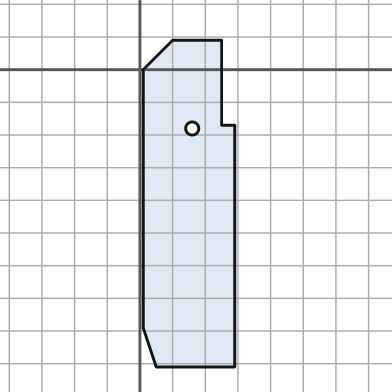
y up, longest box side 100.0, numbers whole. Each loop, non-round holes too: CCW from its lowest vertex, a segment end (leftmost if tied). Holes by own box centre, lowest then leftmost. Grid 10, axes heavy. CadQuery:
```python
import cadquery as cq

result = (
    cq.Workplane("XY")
    .moveTo(5.0, -91.0)
    .lineTo(29.0, -91.0)
    .lineTo(29.0, -17.0)
    .lineTo(25.0, -17.0)
    .lineTo(25.0, 9.0)
    .lineTo(10.0, 9.0)
    .lineTo(1.0, 0.0)
    .lineTo(1.0, -79.0)
    .close()
    .moveTo(16.0, -18.0)
    .circle(2.0)
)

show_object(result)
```